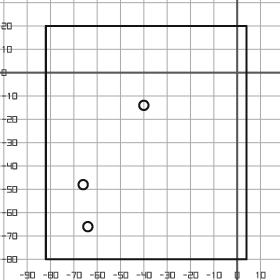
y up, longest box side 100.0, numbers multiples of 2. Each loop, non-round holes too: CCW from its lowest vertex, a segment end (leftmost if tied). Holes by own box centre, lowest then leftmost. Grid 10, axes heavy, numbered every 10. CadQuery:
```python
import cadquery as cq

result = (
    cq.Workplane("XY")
    .moveTo(-82.0, -80.0)
    .lineTo(4.0, -80.0)
    .lineTo(4.0, 20.0)
    .lineTo(-82.0, 20.0)
    .close()
    .moveTo(-64.0, -66.0)
    .circle(2.0)
    .moveTo(-66.0, -48.0)
    .circle(2.0)
    .moveTo(-40.0, -14.0)
    .circle(2.0)
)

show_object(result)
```